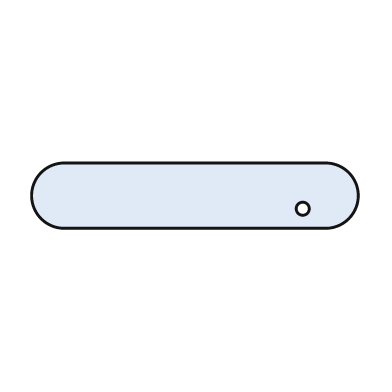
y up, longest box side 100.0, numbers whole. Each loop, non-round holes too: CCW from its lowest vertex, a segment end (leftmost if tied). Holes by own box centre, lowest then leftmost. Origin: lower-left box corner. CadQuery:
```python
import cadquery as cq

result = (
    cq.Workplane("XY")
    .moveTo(10.0, 0.0)
    .lineTo(90.0, 0.0)
    .threePointArc((100.0, 10.0), (90.0, 20.0))
    .lineTo(10.0, 20.0)
    .threePointArc((0.0, 10.0), (10.0, 0.0))
    .close()
    .moveTo(83.0, 6.0)
    .circle(2.0)
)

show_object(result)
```